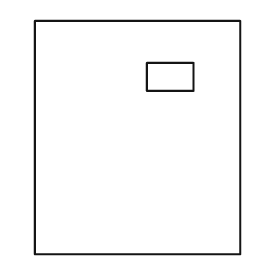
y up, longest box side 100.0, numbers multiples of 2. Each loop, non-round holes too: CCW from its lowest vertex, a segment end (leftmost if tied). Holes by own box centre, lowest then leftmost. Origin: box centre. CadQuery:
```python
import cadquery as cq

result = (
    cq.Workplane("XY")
    .moveTo(-44.0, -50.0)
    .lineTo(44.0, -50.0)
    .lineTo(44.0, 50.0)
    .lineTo(-44.0, 50.0)
    .close()
    .moveTo(4.0, 20.0)
    .lineTo(24.0, 20.0)
    .lineTo(24.0, 32.0)
    .lineTo(4.0, 32.0)
    .close()
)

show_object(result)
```